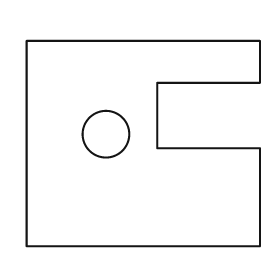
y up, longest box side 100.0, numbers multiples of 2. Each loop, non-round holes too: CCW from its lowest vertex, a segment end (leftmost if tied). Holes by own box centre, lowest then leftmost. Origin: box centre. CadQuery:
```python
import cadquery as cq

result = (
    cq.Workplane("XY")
    .moveTo(-50.0, -44.0)
    .lineTo(50.0, -44.0)
    .lineTo(50.0, -2.0)
    .lineTo(6.0, -2.0)
    .lineTo(6.0, 26.0)
    .lineTo(50.0, 26.0)
    .lineTo(50.0, 44.0)
    .lineTo(-50.0, 44.0)
    .close()
    .moveTo(-16.0, 4.0)
    .circle(10.0)
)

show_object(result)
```